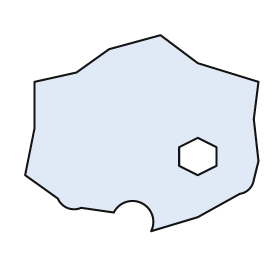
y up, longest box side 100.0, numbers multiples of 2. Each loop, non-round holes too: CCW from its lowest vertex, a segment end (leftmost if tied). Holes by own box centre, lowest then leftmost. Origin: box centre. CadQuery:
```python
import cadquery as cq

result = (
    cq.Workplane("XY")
    .moveTo(4.0, -42.0)
    .lineTo(24.0, -36.0)
    .lineTo(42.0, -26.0)
    .threePointArc((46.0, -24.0), (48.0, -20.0))
    .lineTo(50.0, -12.0)
    .lineTo(48.0, 6.0)
    .lineTo(50.0, 22.0)
    .lineTo(24.0, 30.0)
    .lineTo(8.0, 42.0)
    .lineTo(-14.0, 36.0)
    .lineTo(-28.0, 26.0)
    .lineTo(-46.0, 22.0)
    .lineTo(-46.0, 2.0)
    .lineTo(-50.0, -18.0)
    .lineTo(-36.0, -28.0)
    .threePointArc((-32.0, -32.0), (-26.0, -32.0))
    .lineTo(-12.0, -34.0)
    .threePointArc((0.0, -30.0), (4.0, -42.0))
    .close()
    .moveTo(24.0, -18.0)
    .lineTo(32.0, -14.0)
    .lineTo(32.0, -6.0)
    .lineTo(24.0, -2.0)
    .lineTo(16.0, -6.0)
    .lineTo(16.0, -14.0)
    .close()
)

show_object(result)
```